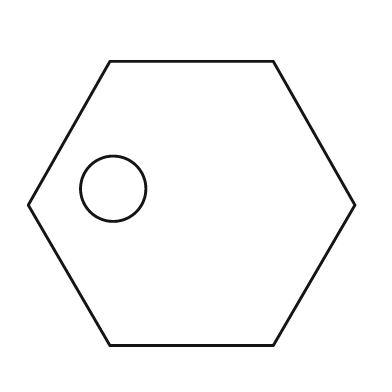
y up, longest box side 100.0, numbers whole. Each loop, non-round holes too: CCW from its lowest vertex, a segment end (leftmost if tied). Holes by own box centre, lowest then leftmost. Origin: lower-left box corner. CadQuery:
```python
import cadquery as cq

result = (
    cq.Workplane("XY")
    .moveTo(25.0, 0.0)
    .lineTo(75.0, 0.0)
    .lineTo(100.0, 43.0)
    .lineTo(75.0, 87.0)
    .lineTo(25.0, 87.0)
    .lineTo(0.0, 43.0)
    .close()
    .moveTo(26.0, 48.0)
    .circle(10.0)
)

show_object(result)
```